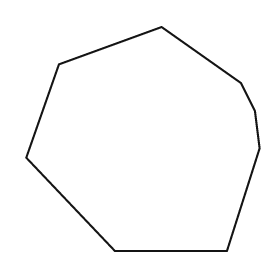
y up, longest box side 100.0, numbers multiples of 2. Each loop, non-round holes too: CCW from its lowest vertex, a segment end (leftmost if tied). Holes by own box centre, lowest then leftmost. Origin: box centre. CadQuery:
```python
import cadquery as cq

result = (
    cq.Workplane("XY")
    .moveTo(-12.0, -48.0)
    .lineTo(36.0, -48.0)
    .lineTo(50.0, -4.0)
    .lineTo(48.0, 12.0)
    .lineTo(42.0, 24.0)
    .lineTo(8.0, 48.0)
    .lineTo(-36.0, 32.0)
    .lineTo(-50.0, -8.0)
    .close()
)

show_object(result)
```